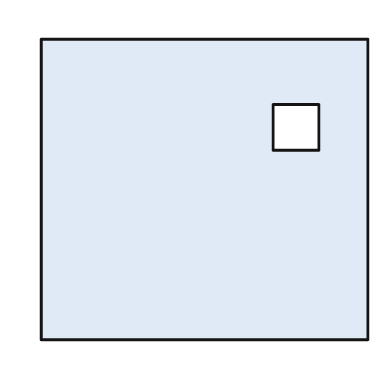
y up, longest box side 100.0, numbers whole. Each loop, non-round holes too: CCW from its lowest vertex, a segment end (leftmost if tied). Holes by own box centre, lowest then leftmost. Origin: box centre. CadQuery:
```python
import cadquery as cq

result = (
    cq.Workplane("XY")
    .moveTo(-50.0, -46.0)
    .lineTo(50.0, -46.0)
    .lineTo(50.0, 46.0)
    .lineTo(-50.0, 46.0)
    .close()
    .moveTo(21.0, 12.0)
    .lineTo(35.0, 12.0)
    .lineTo(35.0, 26.0)
    .lineTo(21.0, 26.0)
    .close()
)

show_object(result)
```